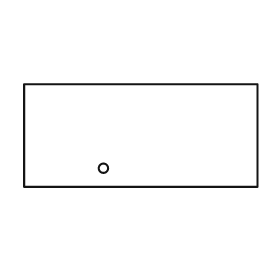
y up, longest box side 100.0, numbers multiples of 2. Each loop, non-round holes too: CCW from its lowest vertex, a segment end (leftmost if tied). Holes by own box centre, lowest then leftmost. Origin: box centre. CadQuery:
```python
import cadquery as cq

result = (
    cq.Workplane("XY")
    .moveTo(-50.0, -22.0)
    .lineTo(50.0, -22.0)
    .lineTo(50.0, 22.0)
    .lineTo(-50.0, 22.0)
    .close()
    .moveTo(-16.0, -14.0)
    .circle(2.0)
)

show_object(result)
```